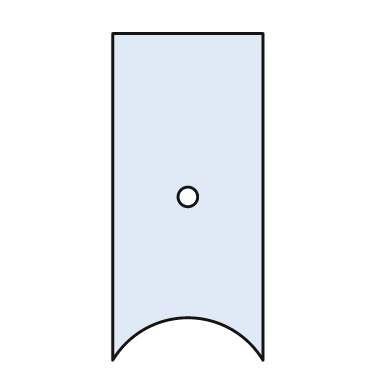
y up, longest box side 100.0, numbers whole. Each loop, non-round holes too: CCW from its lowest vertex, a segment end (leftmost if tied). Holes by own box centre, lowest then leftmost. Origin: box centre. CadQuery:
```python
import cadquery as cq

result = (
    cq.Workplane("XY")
    .moveTo(-23.0, -50.0)
    .threePointArc((0.0, -37.0), (23.0, -50.0))
    .lineTo(23.0, 50.0)
    .lineTo(-23.0, 50.0)
    .close()
    .moveTo(0.0, 0.0)
    .circle(3.0)
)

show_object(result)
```